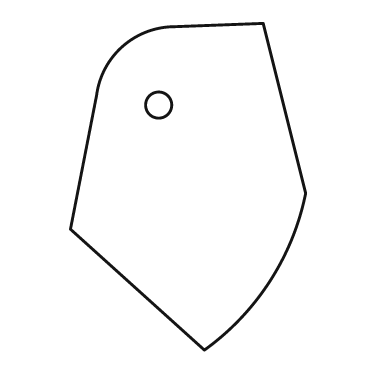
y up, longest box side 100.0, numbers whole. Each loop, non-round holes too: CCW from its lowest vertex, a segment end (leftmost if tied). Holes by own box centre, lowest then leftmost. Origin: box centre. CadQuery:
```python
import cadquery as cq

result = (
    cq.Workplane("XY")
    .moveTo(5.0, -50.0)
    .threePointArc((25.0, -29.0), (36.0, -2.0))
    .lineTo(23.0, 50.0)
    .lineTo(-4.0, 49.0)
    .threePointArc((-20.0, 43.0), (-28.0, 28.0))
    .lineTo(-36.0, -13.0)
    .close()
    .moveTo(-9.0, 25.0)
    .circle(4.0)
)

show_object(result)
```